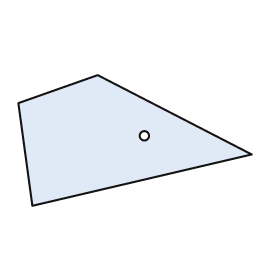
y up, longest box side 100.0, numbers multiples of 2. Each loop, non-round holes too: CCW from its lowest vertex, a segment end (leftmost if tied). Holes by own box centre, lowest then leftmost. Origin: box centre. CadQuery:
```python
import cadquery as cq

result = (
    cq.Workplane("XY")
    .moveTo(-44.0, -28.0)
    .lineTo(50.0, -6.0)
    .lineTo(-16.0, 28.0)
    .lineTo(-50.0, 16.0)
    .close()
    .moveTo(4.0, 2.0)
    .circle(2.0)
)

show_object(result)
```